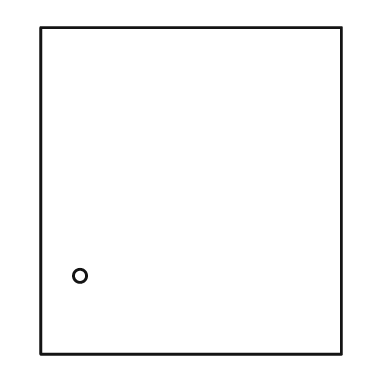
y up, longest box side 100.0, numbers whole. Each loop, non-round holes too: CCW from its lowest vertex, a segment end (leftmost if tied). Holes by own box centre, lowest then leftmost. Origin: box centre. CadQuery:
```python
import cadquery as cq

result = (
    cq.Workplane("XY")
    .moveTo(-46.0, -50.0)
    .lineTo(46.0, -50.0)
    .lineTo(46.0, 50.0)
    .lineTo(-46.0, 50.0)
    .close()
    .moveTo(-34.0, -26.0)
    .circle(2.0)
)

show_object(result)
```